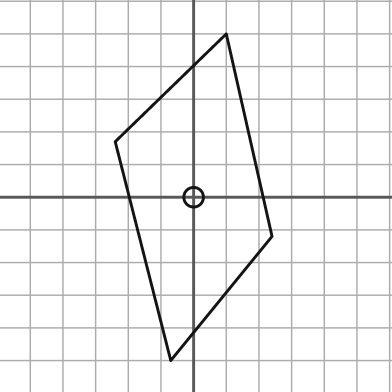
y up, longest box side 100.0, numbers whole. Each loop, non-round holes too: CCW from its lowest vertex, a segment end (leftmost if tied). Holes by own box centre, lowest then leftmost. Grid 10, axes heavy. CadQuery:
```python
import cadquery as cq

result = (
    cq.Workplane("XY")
    .moveTo(-7.0, -50.0)
    .lineTo(24.0, -12.0)
    .lineTo(10.0, 50.0)
    .lineTo(-24.0, 17.0)
    .close()
    .moveTo(0.0, 0.0)
    .circle(3.0)
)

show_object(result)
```